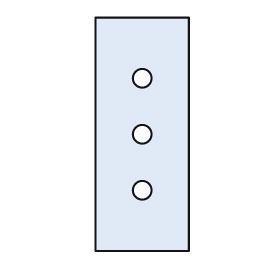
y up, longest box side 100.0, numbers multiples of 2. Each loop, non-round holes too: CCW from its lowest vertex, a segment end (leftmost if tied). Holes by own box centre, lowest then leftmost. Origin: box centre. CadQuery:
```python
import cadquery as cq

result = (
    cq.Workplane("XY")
    .moveTo(-20.0, -50.0)
    .lineTo(20.0, -50.0)
    .lineTo(20.0, 50.0)
    .lineTo(-20.0, 50.0)
    .close()
    .moveTo(0.0, -24.0)
    .circle(4.0)
    .moveTo(0.0, 0.0)
    .circle(4.0)
    .moveTo(0.0, 24.0)
    .circle(4.0)
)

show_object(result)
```